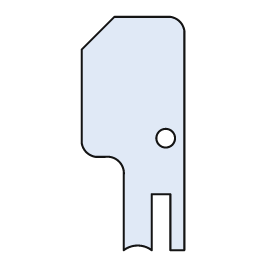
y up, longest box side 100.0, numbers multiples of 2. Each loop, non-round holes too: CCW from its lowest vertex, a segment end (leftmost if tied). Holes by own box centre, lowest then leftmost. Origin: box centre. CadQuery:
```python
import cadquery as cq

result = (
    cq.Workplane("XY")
    .moveTo(-4.0, -50.0)
    .threePointArc((2.0, -48.0), (8.0, -50.0))
    .lineTo(8.0, -26.0)
    .lineTo(16.0, -26.0)
    .lineTo(16.0, -50.0)
    .lineTo(22.0, -50.0)
    .lineTo(22.0, 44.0)
    .threePointArc((20.0, 48.0), (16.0, 50.0))
    .lineTo(-8.0, 50.0)
    .lineTo(-22.0, 36.0)
    .lineTo(-22.0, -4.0)
    .threePointArc((-20.0, -8.0), (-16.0, -10.0))
    .lineTo(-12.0, -10.0)
    .threePointArc((-6.0, -12.0), (-4.0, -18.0))
    .close()
    .moveTo(14.0, -2.0)
    .circle(4.0)
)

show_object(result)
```